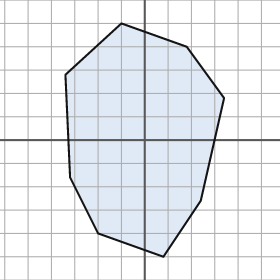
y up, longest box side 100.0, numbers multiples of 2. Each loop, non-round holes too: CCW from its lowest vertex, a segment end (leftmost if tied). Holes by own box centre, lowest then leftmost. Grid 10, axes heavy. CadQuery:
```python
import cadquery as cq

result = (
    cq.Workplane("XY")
    .moveTo(8.0, -50.0)
    .lineTo(24.0, -26.0)
    .lineTo(34.0, 18.0)
    .lineTo(18.0, 40.0)
    .lineTo(-10.0, 50.0)
    .lineTo(-34.0, 28.0)
    .lineTo(-32.0, -16.0)
    .lineTo(-20.0, -40.0)
    .close()
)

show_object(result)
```